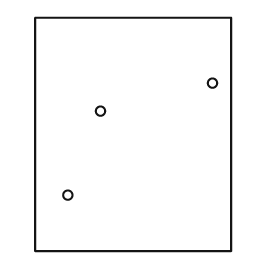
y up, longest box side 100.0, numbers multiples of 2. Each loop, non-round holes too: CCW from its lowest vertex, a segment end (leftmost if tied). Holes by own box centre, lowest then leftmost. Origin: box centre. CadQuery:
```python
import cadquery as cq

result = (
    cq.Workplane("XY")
    .moveTo(-42.0, -50.0)
    .lineTo(42.0, -50.0)
    .lineTo(42.0, 50.0)
    .lineTo(-42.0, 50.0)
    .close()
    .moveTo(-28.0, -26.0)
    .circle(2.0)
    .moveTo(-14.0, 10.0)
    .circle(2.0)
    .moveTo(34.0, 22.0)
    .circle(2.0)
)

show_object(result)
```